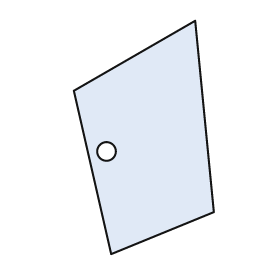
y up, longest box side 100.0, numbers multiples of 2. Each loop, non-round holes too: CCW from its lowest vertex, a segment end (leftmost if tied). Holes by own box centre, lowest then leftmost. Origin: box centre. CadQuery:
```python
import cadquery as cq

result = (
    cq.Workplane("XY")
    .moveTo(-14.0, -50.0)
    .lineTo(30.0, -32.0)
    .lineTo(22.0, 50.0)
    .lineTo(-30.0, 20.0)
    .close()
    .moveTo(-16.0, -6.0)
    .circle(4.0)
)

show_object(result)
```